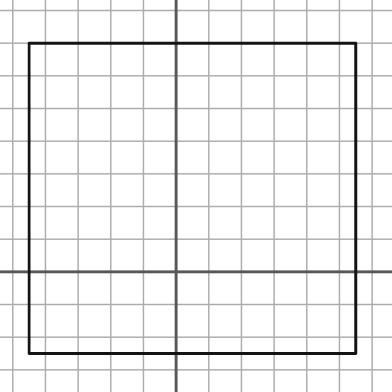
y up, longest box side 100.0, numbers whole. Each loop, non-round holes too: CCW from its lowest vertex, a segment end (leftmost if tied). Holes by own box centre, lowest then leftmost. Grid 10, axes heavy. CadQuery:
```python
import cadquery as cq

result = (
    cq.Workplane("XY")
    .moveTo(-45.0, -25.0)
    .lineTo(55.0, -25.0)
    .lineTo(55.0, 70.0)
    .lineTo(-45.0, 70.0)
    .close()
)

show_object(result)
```